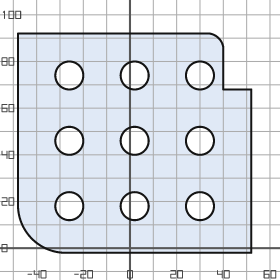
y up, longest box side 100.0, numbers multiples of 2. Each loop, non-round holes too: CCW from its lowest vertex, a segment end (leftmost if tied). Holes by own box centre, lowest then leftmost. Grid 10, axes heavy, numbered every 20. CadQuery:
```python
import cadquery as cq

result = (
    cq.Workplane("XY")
    .moveTo(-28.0, -2.0)
    .lineTo(52.0, -2.0)
    .lineTo(52.0, 68.0)
    .lineTo(40.0, 68.0)
    .lineTo(40.0, 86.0)
    .threePointArc((38.0, 90.0), (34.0, 92.0))
    .lineTo(-48.0, 92.0)
    .lineTo(-48.0, 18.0)
    .threePointArc((-42.0, 4.0), (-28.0, -2.0))
    .close()
    .moveTo(-26.0, 18.0)
    .circle(6.0)
    .moveTo(2.0, 18.0)
    .circle(6.0)
    .moveTo(30.0, 18.0)
    .circle(6.0)
    .moveTo(-26.0, 46.0)
    .circle(6.0)
    .moveTo(2.0, 46.0)
    .circle(6.0)
    .moveTo(30.0, 46.0)
    .circle(6.0)
    .moveTo(-26.0, 74.0)
    .circle(6.0)
    .moveTo(2.0, 74.0)
    .circle(6.0)
    .moveTo(30.0, 74.0)
    .circle(6.0)
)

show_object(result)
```